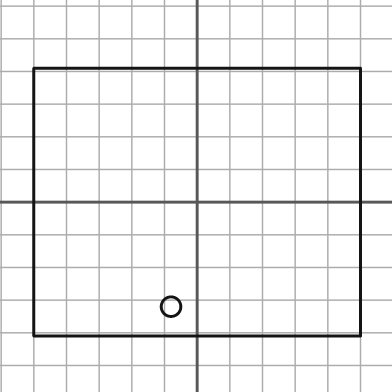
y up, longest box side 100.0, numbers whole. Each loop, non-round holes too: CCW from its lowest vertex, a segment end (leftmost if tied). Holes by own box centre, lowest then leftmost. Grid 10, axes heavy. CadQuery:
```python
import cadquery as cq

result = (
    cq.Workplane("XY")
    .moveTo(-50.0, -41.0)
    .lineTo(50.0, -41.0)
    .lineTo(50.0, 41.0)
    .lineTo(-50.0, 41.0)
    .close()
    .moveTo(-8.0, -32.0)
    .circle(3.0)
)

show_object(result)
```